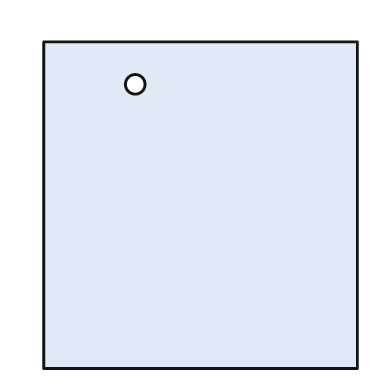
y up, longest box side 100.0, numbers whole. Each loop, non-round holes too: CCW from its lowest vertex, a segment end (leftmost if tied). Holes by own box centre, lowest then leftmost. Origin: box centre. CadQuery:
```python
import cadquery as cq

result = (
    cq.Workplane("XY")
    .moveTo(-48.0, -50.0)
    .lineTo(48.0, -50.0)
    .lineTo(48.0, 50.0)
    .lineTo(-48.0, 50.0)
    .close()
    .moveTo(-20.0, 37.0)
    .circle(3.0)
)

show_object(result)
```